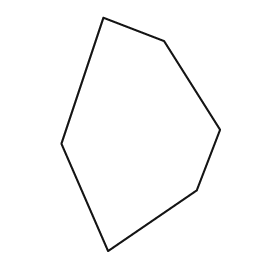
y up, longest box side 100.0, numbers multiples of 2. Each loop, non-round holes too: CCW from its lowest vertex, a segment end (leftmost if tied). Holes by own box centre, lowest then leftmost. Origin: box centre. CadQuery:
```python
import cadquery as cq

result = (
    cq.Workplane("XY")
    .moveTo(-14.0, -50.0)
    .lineTo(24.0, -24.0)
    .lineTo(34.0, 2.0)
    .lineTo(10.0, 40.0)
    .lineTo(-16.0, 50.0)
    .lineTo(-34.0, -4.0)
    .close()
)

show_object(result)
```